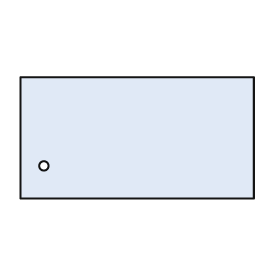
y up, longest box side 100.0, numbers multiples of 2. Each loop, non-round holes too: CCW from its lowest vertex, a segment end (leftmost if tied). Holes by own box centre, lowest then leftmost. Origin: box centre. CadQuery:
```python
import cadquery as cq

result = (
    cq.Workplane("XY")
    .moveTo(-50.0, -26.0)
    .lineTo(50.0, -26.0)
    .lineTo(50.0, 26.0)
    .lineTo(-50.0, 26.0)
    .close()
    .moveTo(-40.0, -12.0)
    .circle(2.0)
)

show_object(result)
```